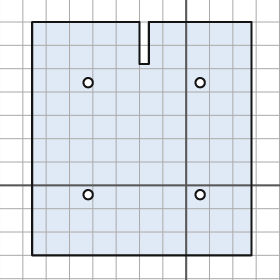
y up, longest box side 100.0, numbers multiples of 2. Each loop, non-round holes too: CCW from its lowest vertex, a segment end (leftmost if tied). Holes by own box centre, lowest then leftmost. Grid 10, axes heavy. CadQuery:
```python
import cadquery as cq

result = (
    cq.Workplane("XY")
    .moveTo(-66.0, -30.0)
    .lineTo(28.0, -30.0)
    .lineTo(28.0, 70.0)
    .lineTo(-16.0, 70.0)
    .lineTo(-16.0, 52.0)
    .lineTo(-20.0, 52.0)
    .lineTo(-20.0, 70.0)
    .lineTo(-66.0, 70.0)
    .close()
    .moveTo(-42.0, -4.0)
    .circle(2.0)
    .moveTo(6.0, -4.0)
    .circle(2.0)
    .moveTo(-42.0, 44.0)
    .circle(2.0)
    .moveTo(6.0, 44.0)
    .circle(2.0)
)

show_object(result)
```